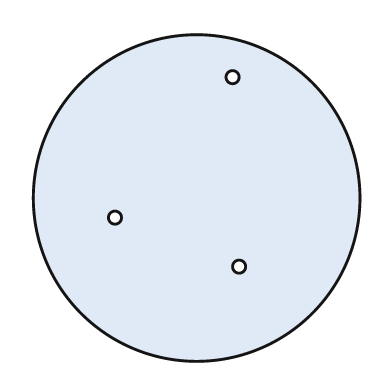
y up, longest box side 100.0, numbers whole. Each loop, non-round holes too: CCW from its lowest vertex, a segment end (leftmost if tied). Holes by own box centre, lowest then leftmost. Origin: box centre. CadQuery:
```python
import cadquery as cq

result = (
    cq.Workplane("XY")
    .moveTo(0.0, 0.0)
    .circle(50.0)
    .moveTo(13.0, -21.0)
    .circle(2.0)
    .moveTo(-25.0, -6.0)
    .circle(2.0)
    .moveTo(11.0, 37.0)
    .circle(2.0)
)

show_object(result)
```